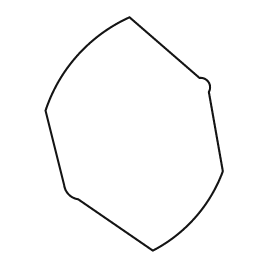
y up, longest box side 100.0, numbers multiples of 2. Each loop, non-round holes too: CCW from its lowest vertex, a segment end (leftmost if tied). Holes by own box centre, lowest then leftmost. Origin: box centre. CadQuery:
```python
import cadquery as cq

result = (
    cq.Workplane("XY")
    .moveTo(8.0, -50.0)
    .threePointArc((26.0, -36.0), (38.0, -16.0))
    .lineTo(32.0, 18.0)
    .threePointArc((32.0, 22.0), (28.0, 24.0))
    .lineTo(-2.0, 50.0)
    .threePointArc((-24.0, 34.0), (-38.0, 10.0))
    .lineTo(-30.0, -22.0)
    .threePointArc((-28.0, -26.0), (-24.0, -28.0))
    .close()
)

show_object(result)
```